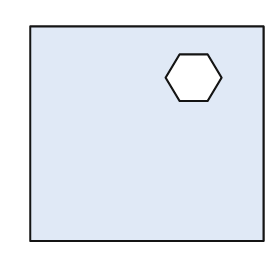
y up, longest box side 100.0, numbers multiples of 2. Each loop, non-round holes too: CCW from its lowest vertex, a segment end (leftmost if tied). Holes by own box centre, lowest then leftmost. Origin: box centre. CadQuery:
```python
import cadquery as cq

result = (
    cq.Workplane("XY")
    .moveTo(-50.0, -46.0)
    .lineTo(50.0, -46.0)
    .lineTo(50.0, 46.0)
    .lineTo(-50.0, 46.0)
    .close()
    .moveTo(14.0, 14.0)
    .lineTo(26.0, 14.0)
    .lineTo(32.0, 24.0)
    .lineTo(26.0, 34.0)
    .lineTo(14.0, 34.0)
    .lineTo(8.0, 24.0)
    .close()
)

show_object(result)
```